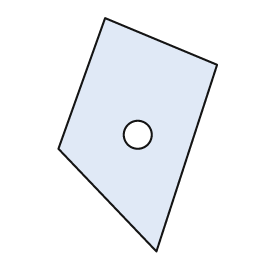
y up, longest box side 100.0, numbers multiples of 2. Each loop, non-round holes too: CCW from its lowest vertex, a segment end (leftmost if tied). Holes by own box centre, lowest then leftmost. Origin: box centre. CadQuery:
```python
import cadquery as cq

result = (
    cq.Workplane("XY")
    .moveTo(8.0, -50.0)
    .lineTo(34.0, 30.0)
    .lineTo(-14.0, 50.0)
    .lineTo(-34.0, -6.0)
    .close()
    .moveTo(0.0, 0.0)
    .circle(6.0)
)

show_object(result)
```